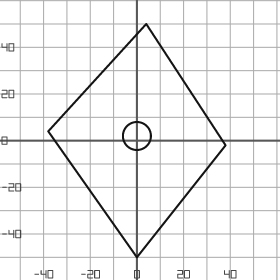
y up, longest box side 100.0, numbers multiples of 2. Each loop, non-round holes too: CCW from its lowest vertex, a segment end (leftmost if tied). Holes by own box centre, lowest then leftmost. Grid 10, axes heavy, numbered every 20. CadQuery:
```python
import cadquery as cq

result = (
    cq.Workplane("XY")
    .moveTo(0.0, -50.0)
    .lineTo(38.0, -2.0)
    .lineTo(4.0, 50.0)
    .lineTo(-38.0, 4.0)
    .close()
    .moveTo(0.0, 2.0)
    .circle(6.0)
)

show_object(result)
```